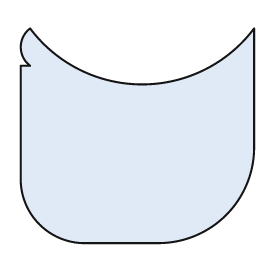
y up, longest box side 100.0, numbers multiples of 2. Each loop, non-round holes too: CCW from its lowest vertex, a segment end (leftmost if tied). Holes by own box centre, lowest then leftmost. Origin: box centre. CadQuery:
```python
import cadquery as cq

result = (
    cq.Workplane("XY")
    .moveTo(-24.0, -46.0)
    .lineTo(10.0, -46.0)
    .threePointArc((38.0, -34.0), (50.0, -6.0))
    .lineTo(50.0, 46.0)
    .threePointArc((2.0, 22.0), (-46.0, 46.0))
    .threePointArc((-50.0, 38.0), (-46.0, 30.0))
    .lineTo(-50.0, 30.0)
    .lineTo(-50.0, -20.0)
    .threePointArc((-42.0, -38.0), (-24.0, -46.0))
    .close()
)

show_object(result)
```